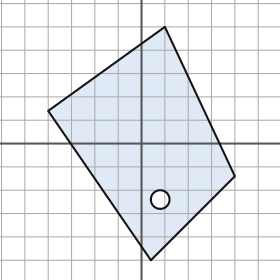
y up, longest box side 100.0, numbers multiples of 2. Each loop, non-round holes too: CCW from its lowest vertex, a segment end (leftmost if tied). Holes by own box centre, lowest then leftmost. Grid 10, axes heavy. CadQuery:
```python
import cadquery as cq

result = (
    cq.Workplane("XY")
    .moveTo(4.0, -50.0)
    .lineTo(40.0, -14.0)
    .lineTo(10.0, 50.0)
    .lineTo(-40.0, 14.0)
    .close()
    .moveTo(8.0, -24.0)
    .circle(4.0)
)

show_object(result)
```